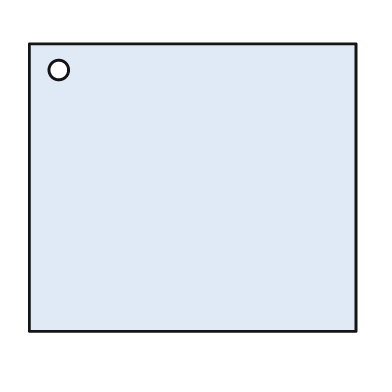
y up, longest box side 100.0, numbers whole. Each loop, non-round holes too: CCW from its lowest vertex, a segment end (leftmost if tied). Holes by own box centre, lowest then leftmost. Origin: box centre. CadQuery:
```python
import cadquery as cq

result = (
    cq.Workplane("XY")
    .moveTo(-50.0, -44.0)
    .lineTo(50.0, -44.0)
    .lineTo(50.0, 44.0)
    .lineTo(-50.0, 44.0)
    .close()
    .moveTo(-41.0, 36.0)
    .circle(3.0)
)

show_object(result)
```